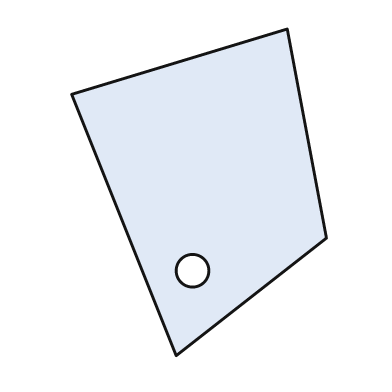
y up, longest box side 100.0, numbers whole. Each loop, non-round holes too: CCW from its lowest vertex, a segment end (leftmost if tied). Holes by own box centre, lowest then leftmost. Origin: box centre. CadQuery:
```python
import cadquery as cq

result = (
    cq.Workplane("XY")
    .moveTo(-7.0, -50.0)
    .lineTo(39.0, -14.0)
    .lineTo(27.0, 50.0)
    .lineTo(-39.0, 30.0)
    .close()
    .moveTo(-2.0, -24.0)
    .circle(5.0)
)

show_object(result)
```